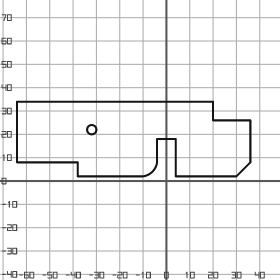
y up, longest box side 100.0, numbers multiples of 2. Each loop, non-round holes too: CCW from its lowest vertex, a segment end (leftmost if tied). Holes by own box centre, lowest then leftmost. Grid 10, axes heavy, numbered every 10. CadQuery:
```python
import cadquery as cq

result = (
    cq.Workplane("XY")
    .moveTo(-38.0, 2.0)
    .lineTo(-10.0, 2.0)
    .threePointArc((-6.0, 4.0), (-4.0, 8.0))
    .lineTo(-4.0, 18.0)
    .lineTo(4.0, 18.0)
    .lineTo(4.0, 2.0)
    .lineTo(30.0, 2.0)
    .lineTo(36.0, 8.0)
    .lineTo(36.0, 26.0)
    .lineTo(20.0, 26.0)
    .lineTo(20.0, 34.0)
    .lineTo(-64.0, 34.0)
    .lineTo(-64.0, 8.0)
    .lineTo(-38.0, 8.0)
    .close()
    .moveTo(-32.0, 22.0)
    .circle(2.0)
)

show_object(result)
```